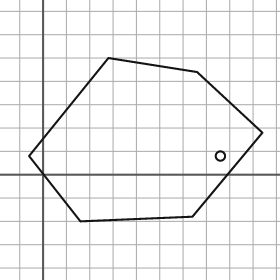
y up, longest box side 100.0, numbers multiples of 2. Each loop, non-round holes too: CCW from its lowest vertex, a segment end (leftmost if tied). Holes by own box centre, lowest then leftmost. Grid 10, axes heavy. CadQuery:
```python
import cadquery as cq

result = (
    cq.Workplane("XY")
    .moveTo(16.0, -20.0)
    .lineTo(64.0, -18.0)
    .lineTo(94.0, 18.0)
    .lineTo(66.0, 44.0)
    .lineTo(28.0, 50.0)
    .lineTo(-6.0, 8.0)
    .close()
    .moveTo(76.0, 8.0)
    .circle(2.0)
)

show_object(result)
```